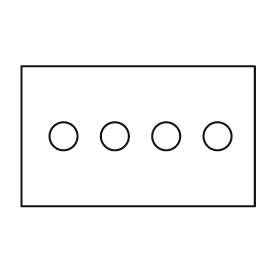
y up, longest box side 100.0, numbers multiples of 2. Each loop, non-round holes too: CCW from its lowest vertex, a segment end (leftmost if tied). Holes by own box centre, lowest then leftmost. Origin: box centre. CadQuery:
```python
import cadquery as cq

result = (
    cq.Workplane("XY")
    .moveTo(-50.0, -30.0)
    .lineTo(50.0, -30.0)
    .lineTo(50.0, 30.0)
    .lineTo(-50.0, 30.0)
    .close()
    .moveTo(-32.0, 0.0)
    .circle(6.0)
    .moveTo(-10.0, 0.0)
    .circle(6.0)
    .moveTo(12.0, 0.0)
    .circle(6.0)
    .moveTo(34.0, 0.0)
    .circle(6.0)
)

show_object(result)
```